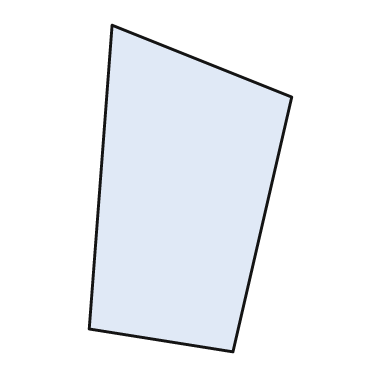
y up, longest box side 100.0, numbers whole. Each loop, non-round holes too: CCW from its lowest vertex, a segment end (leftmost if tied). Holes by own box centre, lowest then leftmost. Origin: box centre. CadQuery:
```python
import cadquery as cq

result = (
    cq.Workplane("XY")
    .moveTo(13.0, -50.0)
    .lineTo(31.0, 28.0)
    .lineTo(-24.0, 50.0)
    .lineTo(-31.0, -43.0)
    .close()
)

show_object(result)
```